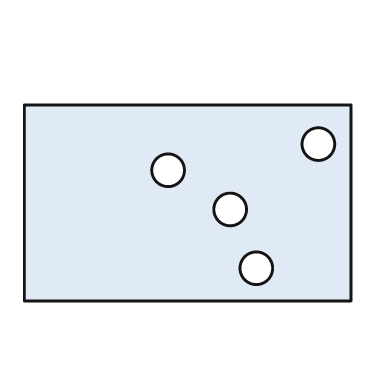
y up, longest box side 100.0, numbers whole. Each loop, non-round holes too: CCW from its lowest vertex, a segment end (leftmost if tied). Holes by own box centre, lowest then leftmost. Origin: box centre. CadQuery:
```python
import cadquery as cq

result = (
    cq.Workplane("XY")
    .moveTo(-50.0, -30.0)
    .lineTo(50.0, -30.0)
    .lineTo(50.0, 30.0)
    .lineTo(-50.0, 30.0)
    .close()
    .moveTo(21.0, -20.0)
    .circle(5.0)
    .moveTo(13.0, -2.0)
    .circle(5.0)
    .moveTo(-6.0, 10.0)
    .circle(5.0)
    .moveTo(40.0, 18.0)
    .circle(5.0)
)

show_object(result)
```